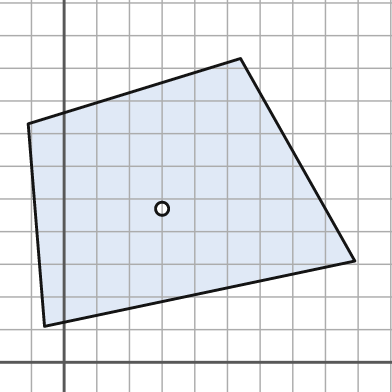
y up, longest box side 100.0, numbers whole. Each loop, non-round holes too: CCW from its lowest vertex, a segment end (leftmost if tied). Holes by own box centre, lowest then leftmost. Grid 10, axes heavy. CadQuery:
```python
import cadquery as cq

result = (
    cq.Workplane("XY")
    .moveTo(-6.0, 11.0)
    .lineTo(89.0, 31.0)
    .lineTo(54.0, 93.0)
    .lineTo(-11.0, 73.0)
    .close()
    .moveTo(30.0, 47.0)
    .circle(2.0)
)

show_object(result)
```